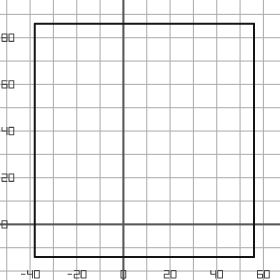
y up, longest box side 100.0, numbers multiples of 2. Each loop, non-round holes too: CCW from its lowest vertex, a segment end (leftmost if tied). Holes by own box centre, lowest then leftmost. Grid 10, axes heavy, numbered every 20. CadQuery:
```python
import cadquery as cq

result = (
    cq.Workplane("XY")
    .moveTo(-38.0, -14.0)
    .lineTo(56.0, -14.0)
    .lineTo(56.0, 86.0)
    .lineTo(-38.0, 86.0)
    .close()
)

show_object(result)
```